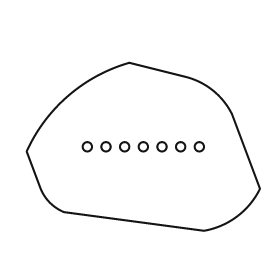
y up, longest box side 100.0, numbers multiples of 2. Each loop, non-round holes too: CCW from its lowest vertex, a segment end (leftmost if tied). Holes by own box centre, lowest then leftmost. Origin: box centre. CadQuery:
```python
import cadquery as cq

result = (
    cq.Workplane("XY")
    .moveTo(26.0, -36.0)
    .threePointArc((40.0, -30.0), (50.0, -18.0))
    .lineTo(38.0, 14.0)
    .threePointArc((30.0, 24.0), (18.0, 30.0))
    .lineTo(-6.0, 36.0)
    .threePointArc((-32.0, 22.0), (-50.0, -2.0))
    .lineTo(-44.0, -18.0)
    .threePointArc((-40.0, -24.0), (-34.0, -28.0))
    .close()
    .moveTo(-24.0, 0.0)
    .circle(2.0)
    .moveTo(-16.0, 0.0)
    .circle(2.0)
    .moveTo(-8.0, 0.0)
    .circle(2.0)
    .moveTo(0.0, 0.0)
    .circle(2.0)
    .moveTo(8.0, 0.0)
    .circle(2.0)
    .moveTo(16.0, 0.0)
    .circle(2.0)
    .moveTo(24.0, 0.0)
    .circle(2.0)
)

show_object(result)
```